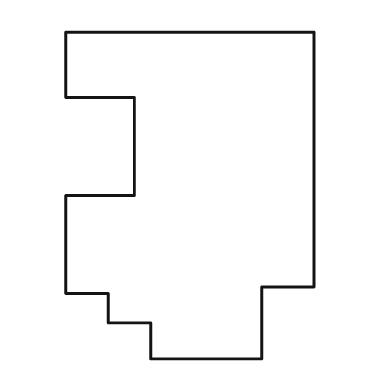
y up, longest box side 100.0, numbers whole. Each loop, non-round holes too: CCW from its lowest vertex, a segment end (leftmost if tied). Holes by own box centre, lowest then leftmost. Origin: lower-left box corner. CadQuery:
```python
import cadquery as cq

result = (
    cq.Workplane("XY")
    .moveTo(26.0, 0.0)
    .lineTo(60.0, 0.0)
    .lineTo(60.0, 22.0)
    .lineTo(76.0, 22.0)
    .lineTo(76.0, 100.0)
    .lineTo(0.0, 100.0)
    .lineTo(0.0, 80.0)
    .lineTo(21.0, 80.0)
    .lineTo(21.0, 50.0)
    .lineTo(0.0, 50.0)
    .lineTo(0.0, 20.0)
    .lineTo(13.0, 20.0)
    .lineTo(13.0, 11.0)
    .lineTo(26.0, 11.0)
    .close()
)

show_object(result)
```